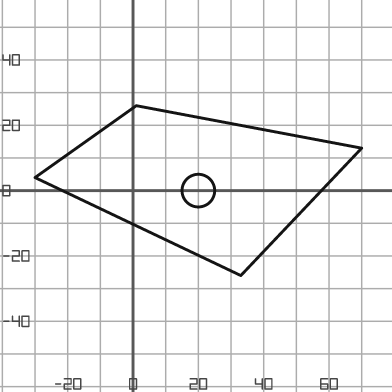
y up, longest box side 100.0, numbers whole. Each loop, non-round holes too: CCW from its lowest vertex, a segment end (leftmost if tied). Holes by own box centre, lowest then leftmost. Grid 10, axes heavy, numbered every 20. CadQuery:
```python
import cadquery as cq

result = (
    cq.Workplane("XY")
    .moveTo(33.0, -26.0)
    .lineTo(70.0, 13.0)
    .lineTo(1.0, 26.0)
    .lineTo(-30.0, 4.0)
    .close()
    .moveTo(20.0, 0.0)
    .circle(5.0)
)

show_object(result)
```